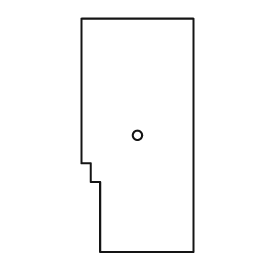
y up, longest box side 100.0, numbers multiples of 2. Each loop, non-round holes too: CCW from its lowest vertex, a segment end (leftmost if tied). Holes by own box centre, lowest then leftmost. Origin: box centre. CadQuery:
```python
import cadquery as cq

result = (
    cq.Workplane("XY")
    .moveTo(-16.0, -50.0)
    .lineTo(24.0, -50.0)
    .lineTo(24.0, 50.0)
    .lineTo(-24.0, 50.0)
    .lineTo(-24.0, -12.0)
    .lineTo(-20.0, -12.0)
    .lineTo(-20.0, -20.0)
    .lineTo(-16.0, -20.0)
    .close()
    .moveTo(0.0, 0.0)
    .circle(2.0)
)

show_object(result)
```